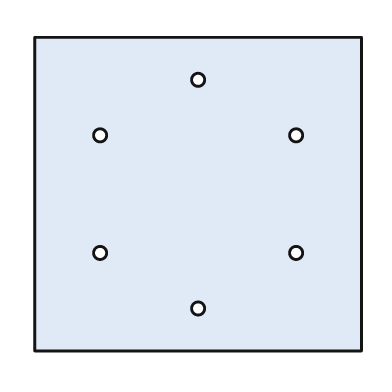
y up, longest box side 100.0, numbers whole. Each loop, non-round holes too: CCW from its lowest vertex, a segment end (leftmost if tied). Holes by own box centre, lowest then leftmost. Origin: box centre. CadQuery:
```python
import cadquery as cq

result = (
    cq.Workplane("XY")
    .moveTo(-50.0, -48.0)
    .lineTo(50.0, -48.0)
    .lineTo(50.0, 48.0)
    .lineTo(-50.0, 48.0)
    .close()
    .moveTo(0.0, -35.0)
    .circle(2.0)
    .moveTo(-30.0, -18.0)
    .circle(2.0)
    .moveTo(30.0, -18.0)
    .circle(2.0)
    .moveTo(-30.0, 18.0)
    .circle(2.0)
    .moveTo(30.0, 18.0)
    .circle(2.0)
    .moveTo(0.0, 35.0)
    .circle(2.0)
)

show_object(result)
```